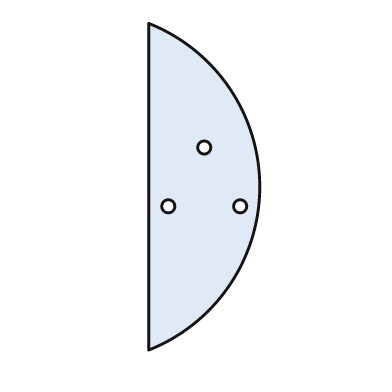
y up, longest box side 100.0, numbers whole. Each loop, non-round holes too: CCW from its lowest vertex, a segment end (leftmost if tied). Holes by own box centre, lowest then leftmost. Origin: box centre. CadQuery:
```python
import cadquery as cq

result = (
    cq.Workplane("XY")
    .moveTo(-17.0, -50.0)
    .threePointArc((17.0, 0.0), (-17.0, 50.0))
    .close()
    .moveTo(-11.0, -6.0)
    .circle(2.0)
    .moveTo(11.0, -6.0)
    .circle(2.0)
    .moveTo(0.0, 12.0)
    .circle(2.0)
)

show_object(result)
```